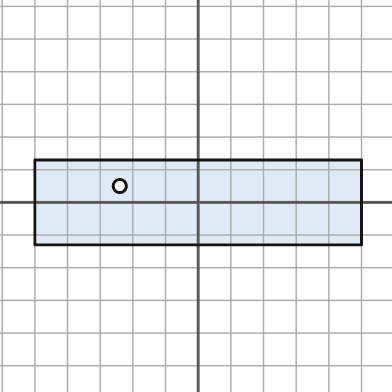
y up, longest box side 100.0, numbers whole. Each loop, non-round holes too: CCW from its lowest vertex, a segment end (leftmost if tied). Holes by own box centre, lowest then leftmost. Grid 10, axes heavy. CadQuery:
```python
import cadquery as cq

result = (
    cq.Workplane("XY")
    .moveTo(-50.0, -13.0)
    .lineTo(50.0, -13.0)
    .lineTo(50.0, 13.0)
    .lineTo(-50.0, 13.0)
    .close()
    .moveTo(-24.0, 5.0)
    .circle(2.0)
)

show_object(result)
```